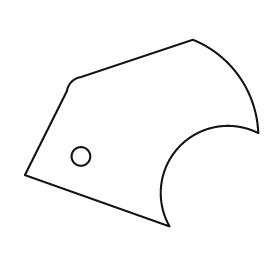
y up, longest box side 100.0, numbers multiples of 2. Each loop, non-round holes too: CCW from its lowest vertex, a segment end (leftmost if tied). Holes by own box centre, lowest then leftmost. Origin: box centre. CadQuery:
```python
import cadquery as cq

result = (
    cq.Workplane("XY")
    .moveTo(12.0, -40.0)
    .threePointArc((16.0, -6.0), (50.0, 0.0))
    .threePointArc((42.0, 24.0), (22.0, 40.0))
    .lineTo(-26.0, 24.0)
    .threePointArc((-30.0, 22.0), (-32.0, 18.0))
    .lineTo(-50.0, -18.0)
    .close()
    .moveTo(-26.0, -10.0)
    .circle(4.0)
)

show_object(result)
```